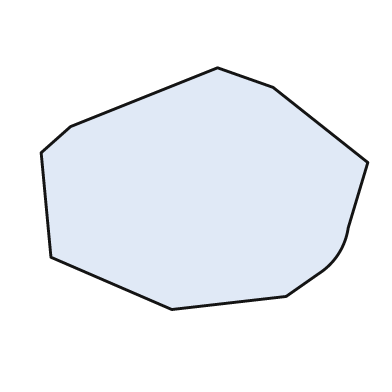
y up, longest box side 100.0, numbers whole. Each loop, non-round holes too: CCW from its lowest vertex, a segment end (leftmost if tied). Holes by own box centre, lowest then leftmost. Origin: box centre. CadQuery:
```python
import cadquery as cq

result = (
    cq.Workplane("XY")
    .moveTo(-10.0, -37.0)
    .lineTo(25.0, -33.0)
    .lineTo(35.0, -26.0)
    .threePointArc((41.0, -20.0), (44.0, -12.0))
    .lineTo(50.0, 8.0)
    .lineTo(21.0, 31.0)
    .lineTo(4.0, 37.0)
    .lineTo(-41.0, 19.0)
    .lineTo(-50.0, 11.0)
    .lineTo(-47.0, -21.0)
    .close()
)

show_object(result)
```